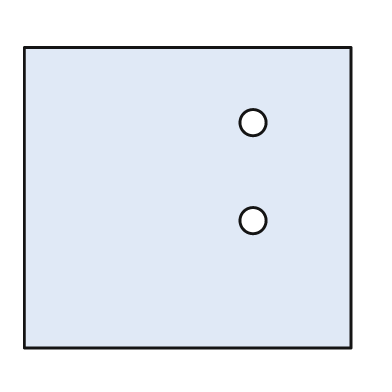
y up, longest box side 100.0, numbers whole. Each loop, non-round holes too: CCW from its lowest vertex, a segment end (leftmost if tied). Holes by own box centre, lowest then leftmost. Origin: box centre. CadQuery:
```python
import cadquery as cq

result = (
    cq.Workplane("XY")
    .moveTo(-50.0, -46.0)
    .lineTo(50.0, -46.0)
    .lineTo(50.0, 46.0)
    .lineTo(-50.0, 46.0)
    .close()
    .moveTo(20.0, -7.0)
    .circle(4.0)
    .moveTo(20.0, 23.0)
    .circle(4.0)
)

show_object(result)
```